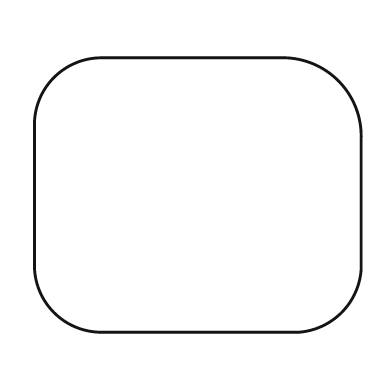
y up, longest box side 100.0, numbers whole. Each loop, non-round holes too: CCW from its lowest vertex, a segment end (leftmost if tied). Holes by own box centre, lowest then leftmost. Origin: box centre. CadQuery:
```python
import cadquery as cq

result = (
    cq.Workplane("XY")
    .moveTo(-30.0, -42.0)
    .lineTo(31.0, -42.0)
    .threePointArc((44.0, -36.0), (50.0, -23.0))
    .lineTo(50.0, 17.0)
    .threePointArc((43.0, 35.0), (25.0, 42.0))
    .lineTo(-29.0, 42.0)
    .threePointArc((-44.0, 36.0), (-50.0, 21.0))
    .lineTo(-50.0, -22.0)
    .threePointArc((-44.0, -36.0), (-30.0, -42.0))
    .close()
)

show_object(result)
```